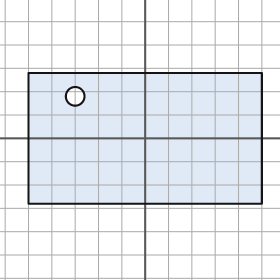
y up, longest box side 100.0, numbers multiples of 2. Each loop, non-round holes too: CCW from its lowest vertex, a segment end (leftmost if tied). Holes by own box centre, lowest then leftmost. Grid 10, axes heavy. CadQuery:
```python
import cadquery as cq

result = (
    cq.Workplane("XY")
    .moveTo(-50.0, -28.0)
    .lineTo(50.0, -28.0)
    .lineTo(50.0, 28.0)
    .lineTo(-50.0, 28.0)
    .close()
    .moveTo(-30.0, 18.0)
    .circle(4.0)
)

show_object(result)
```